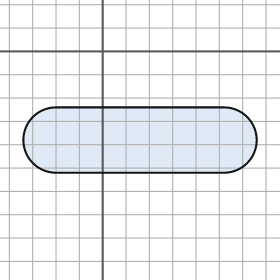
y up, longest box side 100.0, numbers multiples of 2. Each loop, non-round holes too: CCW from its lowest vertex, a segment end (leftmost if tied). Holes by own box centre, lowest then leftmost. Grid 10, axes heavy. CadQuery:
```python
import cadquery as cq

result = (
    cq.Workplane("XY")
    .moveTo(-20.0, -52.0)
    .lineTo(52.0, -52.0)
    .threePointArc((66.0, -38.0), (52.0, -24.0))
    .lineTo(-20.0, -24.0)
    .threePointArc((-34.0, -38.0), (-20.0, -52.0))
    .close()
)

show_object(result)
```